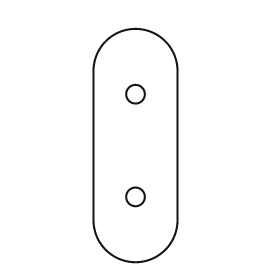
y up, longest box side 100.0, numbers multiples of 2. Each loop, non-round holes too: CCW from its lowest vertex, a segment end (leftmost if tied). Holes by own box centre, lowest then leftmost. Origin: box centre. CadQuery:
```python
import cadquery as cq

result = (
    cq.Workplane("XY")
    .moveTo(-18.0, -32.0)
    .threePointArc((0.0, -50.0), (18.0, -32.0))
    .lineTo(18.0, 32.0)
    .threePointArc((0.0, 50.0), (-18.0, 32.0))
    .close()
    .moveTo(0.0, -22.0)
    .circle(4.0)
    .moveTo(0.0, 22.0)
    .circle(4.0)
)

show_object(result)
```